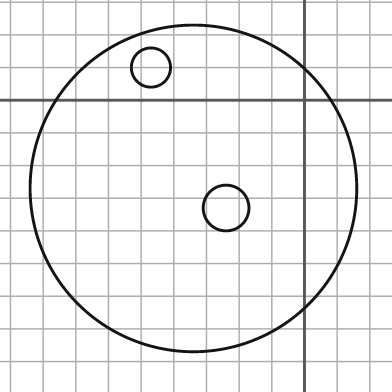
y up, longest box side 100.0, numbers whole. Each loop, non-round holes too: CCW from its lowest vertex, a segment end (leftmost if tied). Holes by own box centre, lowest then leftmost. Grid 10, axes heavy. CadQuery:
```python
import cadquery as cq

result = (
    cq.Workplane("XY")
    .moveTo(-34.0, -27.0)
    .circle(50.0)
    .moveTo(-24.0, -33.0)
    .circle(7.0)
    .moveTo(-47.0, 10.0)
    .circle(6.0)
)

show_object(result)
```